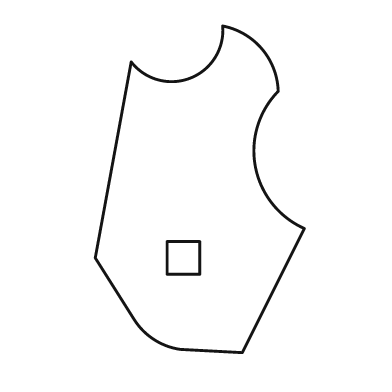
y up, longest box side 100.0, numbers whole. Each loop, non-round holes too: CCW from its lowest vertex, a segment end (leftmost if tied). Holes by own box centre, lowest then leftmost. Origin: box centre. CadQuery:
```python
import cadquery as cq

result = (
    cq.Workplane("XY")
    .moveTo(13.0, -50.0)
    .lineTo(32.0, -12.0)
    .threePointArc((17.0, 7.0), (24.0, 30.0))
    .threePointArc((19.0, 43.0), (7.0, 50.0))
    .threePointArc((-3.0, 34.0), (-21.0, 39.0))
    .lineTo(-32.0, -21.0)
    .lineTo(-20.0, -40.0)
    .threePointArc((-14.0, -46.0), (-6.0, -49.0))
    .close()
    .moveTo(-10.0, -26.0)
    .lineTo(0.0, -26.0)
    .lineTo(0.0, -16.0)
    .lineTo(-10.0, -16.0)
    .close()
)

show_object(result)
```